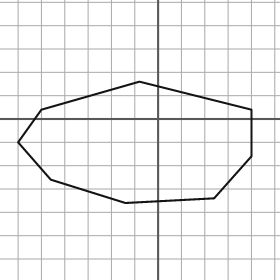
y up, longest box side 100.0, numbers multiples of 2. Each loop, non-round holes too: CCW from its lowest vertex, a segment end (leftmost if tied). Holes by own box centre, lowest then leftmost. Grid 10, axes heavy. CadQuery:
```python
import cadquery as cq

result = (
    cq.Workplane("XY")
    .moveTo(-14.0, -36.0)
    .lineTo(24.0, -34.0)
    .lineTo(40.0, -16.0)
    .lineTo(40.0, 4.0)
    .lineTo(-8.0, 16.0)
    .lineTo(-50.0, 4.0)
    .lineTo(-60.0, -10.0)
    .lineTo(-46.0, -26.0)
    .close()
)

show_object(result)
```